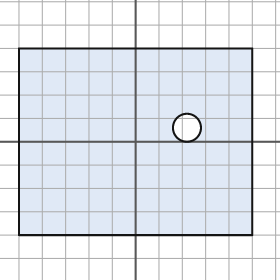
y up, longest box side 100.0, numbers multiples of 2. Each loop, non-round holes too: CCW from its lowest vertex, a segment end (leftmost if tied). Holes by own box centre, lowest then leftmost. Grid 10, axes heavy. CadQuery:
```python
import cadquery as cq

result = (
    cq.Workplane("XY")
    .moveTo(-50.0, -40.0)
    .lineTo(50.0, -40.0)
    .lineTo(50.0, 40.0)
    .lineTo(-50.0, 40.0)
    .close()
    .moveTo(22.0, 6.0)
    .circle(6.0)
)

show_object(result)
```